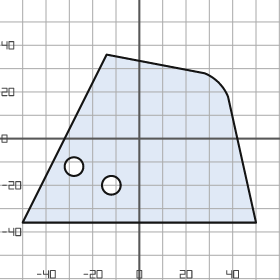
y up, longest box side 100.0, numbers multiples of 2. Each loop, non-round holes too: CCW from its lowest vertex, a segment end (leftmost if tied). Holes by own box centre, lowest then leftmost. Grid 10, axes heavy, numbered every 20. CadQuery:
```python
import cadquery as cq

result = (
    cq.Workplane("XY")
    .moveTo(-50.0, -36.0)
    .lineTo(50.0, -36.0)
    .lineTo(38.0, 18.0)
    .threePointArc((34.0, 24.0), (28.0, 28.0))
    .lineTo(-14.0, 36.0)
    .close()
    .moveTo(-12.0, -20.0)
    .circle(4.0)
    .moveTo(-28.0, -12.0)
    .circle(4.0)
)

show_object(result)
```